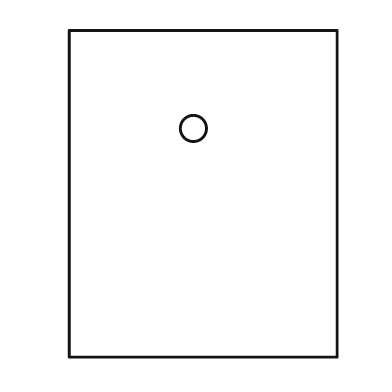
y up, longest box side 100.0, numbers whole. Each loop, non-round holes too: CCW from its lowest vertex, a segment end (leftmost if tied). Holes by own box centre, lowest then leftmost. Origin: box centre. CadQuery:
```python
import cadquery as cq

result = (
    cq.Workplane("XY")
    .moveTo(-41.0, -50.0)
    .lineTo(41.0, -50.0)
    .lineTo(41.0, 50.0)
    .lineTo(-41.0, 50.0)
    .close()
    .moveTo(-3.0, 20.0)
    .circle(4.0)
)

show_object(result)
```